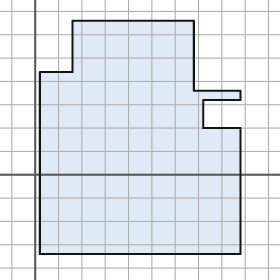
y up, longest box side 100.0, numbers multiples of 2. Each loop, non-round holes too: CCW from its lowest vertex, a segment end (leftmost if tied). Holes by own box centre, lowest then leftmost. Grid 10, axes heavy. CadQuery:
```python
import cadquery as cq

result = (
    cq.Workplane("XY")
    .moveTo(2.0, -34.0)
    .lineTo(88.0, -34.0)
    .lineTo(88.0, 20.0)
    .lineTo(72.0, 20.0)
    .lineTo(72.0, 32.0)
    .lineTo(88.0, 32.0)
    .lineTo(88.0, 36.0)
    .lineTo(68.0, 36.0)
    .lineTo(68.0, 66.0)
    .lineTo(16.0, 66.0)
    .lineTo(16.0, 44.0)
    .lineTo(2.0, 44.0)
    .close()
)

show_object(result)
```